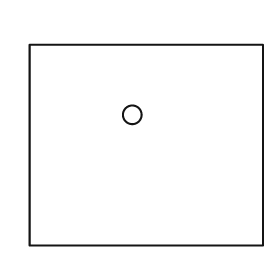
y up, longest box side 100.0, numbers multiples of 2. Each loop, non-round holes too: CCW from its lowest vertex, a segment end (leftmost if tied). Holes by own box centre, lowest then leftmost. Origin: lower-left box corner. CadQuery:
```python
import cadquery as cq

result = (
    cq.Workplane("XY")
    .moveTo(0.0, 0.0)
    .lineTo(100.0, 0.0)
    .lineTo(100.0, 86.0)
    .lineTo(0.0, 86.0)
    .close()
    .moveTo(44.0, 56.0)
    .circle(4.0)
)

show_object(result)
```